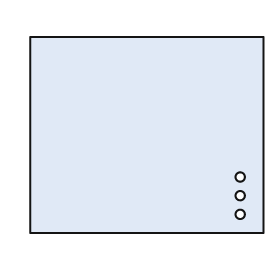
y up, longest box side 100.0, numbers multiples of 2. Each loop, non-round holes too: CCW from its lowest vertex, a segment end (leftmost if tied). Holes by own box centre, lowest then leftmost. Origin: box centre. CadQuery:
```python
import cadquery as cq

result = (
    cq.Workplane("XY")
    .moveTo(-50.0, -42.0)
    .lineTo(50.0, -42.0)
    .lineTo(50.0, 42.0)
    .lineTo(-50.0, 42.0)
    .close()
    .moveTo(40.0, -34.0)
    .circle(2.0)
    .moveTo(40.0, -26.0)
    .circle(2.0)
    .moveTo(40.0, -18.0)
    .circle(2.0)
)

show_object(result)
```